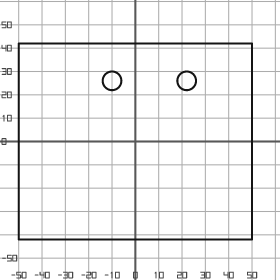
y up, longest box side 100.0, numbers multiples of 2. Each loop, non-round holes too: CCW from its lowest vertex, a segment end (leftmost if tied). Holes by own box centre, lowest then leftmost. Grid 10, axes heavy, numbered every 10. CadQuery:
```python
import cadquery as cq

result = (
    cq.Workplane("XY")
    .moveTo(-50.0, -42.0)
    .lineTo(50.0, -42.0)
    .lineTo(50.0, 42.0)
    .lineTo(-50.0, 42.0)
    .close()
    .moveTo(-10.0, 26.0)
    .circle(4.0)
    .moveTo(22.0, 26.0)
    .circle(4.0)
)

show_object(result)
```